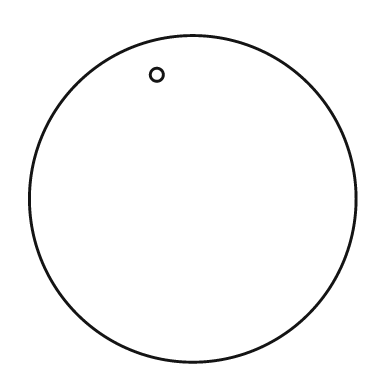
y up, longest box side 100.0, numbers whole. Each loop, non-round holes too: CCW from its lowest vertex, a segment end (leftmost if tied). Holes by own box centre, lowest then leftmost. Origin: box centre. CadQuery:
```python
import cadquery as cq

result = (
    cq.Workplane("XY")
    .moveTo(0.0, 0.0)
    .circle(50.0)
    .moveTo(-11.0, 38.0)
    .circle(2.0)
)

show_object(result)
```